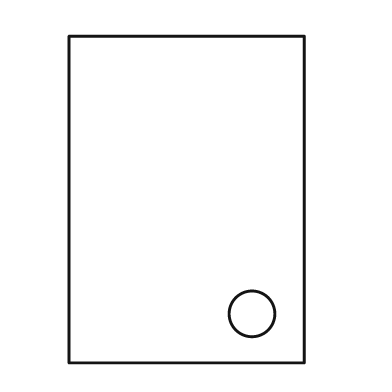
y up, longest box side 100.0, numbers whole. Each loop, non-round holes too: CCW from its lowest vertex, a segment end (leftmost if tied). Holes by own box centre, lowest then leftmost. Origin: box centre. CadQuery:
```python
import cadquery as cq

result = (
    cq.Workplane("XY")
    .moveTo(-36.0, -50.0)
    .lineTo(36.0, -50.0)
    .lineTo(36.0, 50.0)
    .lineTo(-36.0, 50.0)
    .close()
    .moveTo(20.0, -35.0)
    .circle(7.0)
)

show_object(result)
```